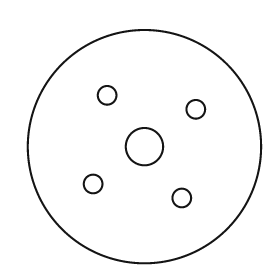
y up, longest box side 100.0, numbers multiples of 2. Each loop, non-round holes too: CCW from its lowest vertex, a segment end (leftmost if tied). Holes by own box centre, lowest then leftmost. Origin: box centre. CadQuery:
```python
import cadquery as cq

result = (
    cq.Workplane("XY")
    .moveTo(0.0, 0.0)
    .circle(50.0)
    .moveTo(16.0, -22.0)
    .circle(4.0)
    .moveTo(-22.0, -16.0)
    .circle(4.0)
    .moveTo(0.0, 0.0)
    .circle(8.0)
    .moveTo(22.0, 16.0)
    .circle(4.0)
    .moveTo(-16.0, 22.0)
    .circle(4.0)
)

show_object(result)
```